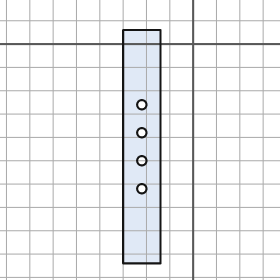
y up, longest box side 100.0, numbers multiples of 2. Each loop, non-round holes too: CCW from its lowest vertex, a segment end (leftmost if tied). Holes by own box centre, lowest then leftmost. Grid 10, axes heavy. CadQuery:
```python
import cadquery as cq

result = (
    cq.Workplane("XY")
    .moveTo(-30.0, -94.0)
    .lineTo(-14.0, -94.0)
    .lineTo(-14.0, 6.0)
    .lineTo(-30.0, 6.0)
    .close()
    .moveTo(-22.0, -62.0)
    .circle(2.0)
    .moveTo(-22.0, -50.0)
    .circle(2.0)
    .moveTo(-22.0, -38.0)
    .circle(2.0)
    .moveTo(-22.0, -26.0)
    .circle(2.0)
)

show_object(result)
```